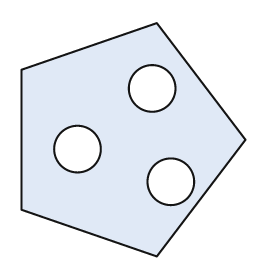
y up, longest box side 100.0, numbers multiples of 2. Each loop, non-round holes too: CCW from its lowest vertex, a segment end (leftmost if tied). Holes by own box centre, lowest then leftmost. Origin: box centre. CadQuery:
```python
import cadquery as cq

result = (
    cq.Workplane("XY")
    .moveTo(10.0, -50.0)
    .lineTo(48.0, 0.0)
    .lineTo(10.0, 50.0)
    .lineTo(-48.0, 30.0)
    .lineTo(-48.0, -30.0)
    .close()
    .moveTo(16.0, -18.0)
    .circle(10.0)
    .moveTo(-24.0, -4.0)
    .circle(10.0)
    .moveTo(8.0, 22.0)
    .circle(10.0)
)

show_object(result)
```